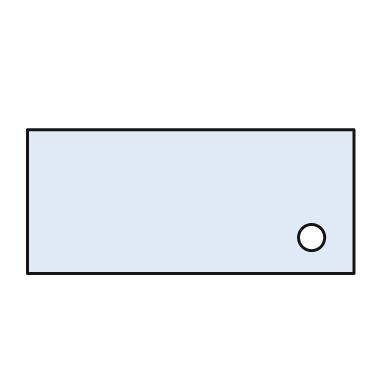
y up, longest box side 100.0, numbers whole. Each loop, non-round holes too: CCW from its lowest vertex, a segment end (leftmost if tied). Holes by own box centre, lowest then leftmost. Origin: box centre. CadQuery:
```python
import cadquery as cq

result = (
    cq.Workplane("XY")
    .moveTo(-50.0, -22.0)
    .lineTo(50.0, -22.0)
    .lineTo(50.0, 22.0)
    .lineTo(-50.0, 22.0)
    .close()
    .moveTo(37.0, -11.0)
    .circle(4.0)
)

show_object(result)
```